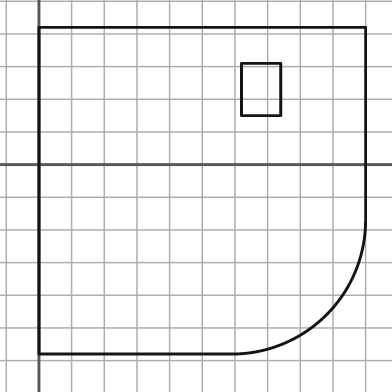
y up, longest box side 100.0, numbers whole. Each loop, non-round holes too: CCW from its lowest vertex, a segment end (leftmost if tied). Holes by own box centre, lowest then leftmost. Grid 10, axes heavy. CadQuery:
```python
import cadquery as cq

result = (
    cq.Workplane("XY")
    .moveTo(0.0, -58.0)
    .lineTo(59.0, -58.0)
    .threePointArc((88.0, -46.0), (100.0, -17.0))
    .lineTo(100.0, 42.0)
    .lineTo(0.0, 42.0)
    .close()
    .moveTo(62.0, 15.0)
    .lineTo(74.0, 15.0)
    .lineTo(74.0, 31.0)
    .lineTo(62.0, 31.0)
    .close()
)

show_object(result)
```